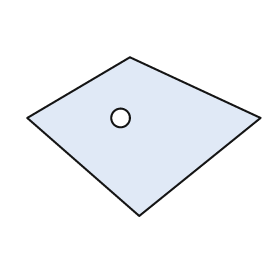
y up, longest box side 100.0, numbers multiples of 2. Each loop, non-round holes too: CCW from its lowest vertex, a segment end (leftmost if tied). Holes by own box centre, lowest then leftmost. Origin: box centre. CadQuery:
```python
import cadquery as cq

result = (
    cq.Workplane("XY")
    .moveTo(-2.0, -34.0)
    .lineTo(50.0, 8.0)
    .lineTo(-6.0, 34.0)
    .lineTo(-50.0, 8.0)
    .close()
    .moveTo(-10.0, 8.0)
    .circle(4.0)
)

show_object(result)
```